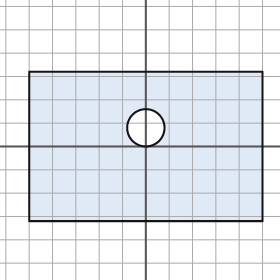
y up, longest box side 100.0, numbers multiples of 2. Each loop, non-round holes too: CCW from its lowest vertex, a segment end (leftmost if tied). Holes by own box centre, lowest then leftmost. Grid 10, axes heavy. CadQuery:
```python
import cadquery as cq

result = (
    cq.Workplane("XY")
    .moveTo(-50.0, -32.0)
    .lineTo(50.0, -32.0)
    .lineTo(50.0, 32.0)
    .lineTo(-50.0, 32.0)
    .close()
    .moveTo(0.0, 8.0)
    .circle(8.0)
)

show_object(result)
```